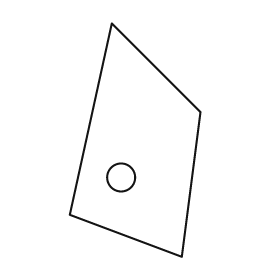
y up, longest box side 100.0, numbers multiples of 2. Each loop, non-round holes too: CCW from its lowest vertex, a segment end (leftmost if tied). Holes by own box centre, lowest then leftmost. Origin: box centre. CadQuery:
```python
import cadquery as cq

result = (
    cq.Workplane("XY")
    .moveTo(20.0, -50.0)
    .lineTo(28.0, 12.0)
    .lineTo(-10.0, 50.0)
    .lineTo(-28.0, -32.0)
    .close()
    .moveTo(-6.0, -16.0)
    .circle(6.0)
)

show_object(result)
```